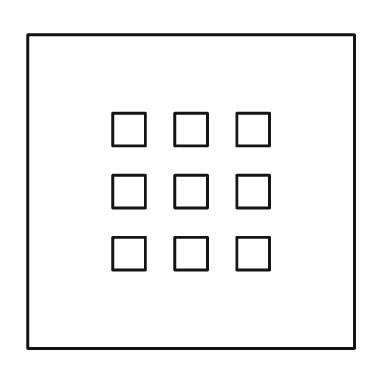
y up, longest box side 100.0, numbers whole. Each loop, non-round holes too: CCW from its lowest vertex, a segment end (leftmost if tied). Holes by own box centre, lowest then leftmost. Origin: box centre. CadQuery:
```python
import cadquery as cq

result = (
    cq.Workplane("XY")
    .moveTo(-50.0, -48.0)
    .lineTo(50.0, -48.0)
    .lineTo(50.0, 48.0)
    .lineTo(-50.0, 48.0)
    .close()
    .moveTo(-24.0, -24.0)
    .lineTo(-14.0, -24.0)
    .lineTo(-14.0, -14.0)
    .lineTo(-24.0, -14.0)
    .close()
    .moveTo(-5.0, -24.0)
    .lineTo(5.0, -24.0)
    .lineTo(5.0, -14.0)
    .lineTo(-5.0, -14.0)
    .close()
    .moveTo(14.0, -24.0)
    .lineTo(24.0, -24.0)
    .lineTo(24.0, -14.0)
    .lineTo(14.0, -14.0)
    .close()
    .moveTo(-24.0, -5.0)
    .lineTo(-14.0, -5.0)
    .lineTo(-14.0, 5.0)
    .lineTo(-24.0, 5.0)
    .close()
    .moveTo(-5.0, -5.0)
    .lineTo(5.0, -5.0)
    .lineTo(5.0, 5.0)
    .lineTo(-5.0, 5.0)
    .close()
    .moveTo(14.0, -5.0)
    .lineTo(24.0, -5.0)
    .lineTo(24.0, 5.0)
    .lineTo(14.0, 5.0)
    .close()
    .moveTo(-24.0, 14.0)
    .lineTo(-14.0, 14.0)
    .lineTo(-14.0, 24.0)
    .lineTo(-24.0, 24.0)
    .close()
    .moveTo(-5.0, 14.0)
    .lineTo(5.0, 14.0)
    .lineTo(5.0, 24.0)
    .lineTo(-5.0, 24.0)
    .close()
    .moveTo(14.0, 14.0)
    .lineTo(24.0, 14.0)
    .lineTo(24.0, 24.0)
    .lineTo(14.0, 24.0)
    .close()
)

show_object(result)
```